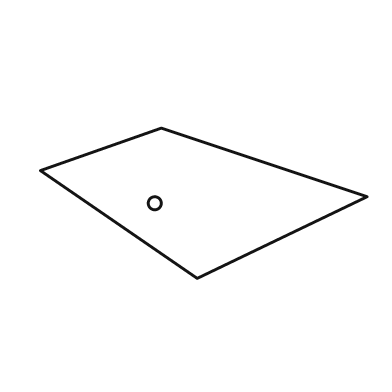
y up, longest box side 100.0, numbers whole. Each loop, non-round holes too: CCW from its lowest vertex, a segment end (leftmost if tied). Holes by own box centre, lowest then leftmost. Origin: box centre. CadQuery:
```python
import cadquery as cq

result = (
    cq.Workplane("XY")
    .moveTo(-2.0, -23.0)
    .lineTo(50.0, 2.0)
    .lineTo(-13.0, 23.0)
    .lineTo(-50.0, 10.0)
    .close()
    .moveTo(-15.0, 0.0)
    .circle(2.0)
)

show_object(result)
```